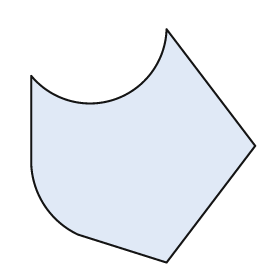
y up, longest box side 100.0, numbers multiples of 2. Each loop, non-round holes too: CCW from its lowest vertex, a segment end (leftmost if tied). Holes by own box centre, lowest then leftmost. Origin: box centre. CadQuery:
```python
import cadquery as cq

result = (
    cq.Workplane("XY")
    .moveTo(10.0, -50.0)
    .lineTo(48.0, 0.0)
    .lineTo(10.0, 50.0)
    .threePointArc((-12.0, 20.0), (-48.0, 30.0))
    .lineTo(-48.0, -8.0)
    .threePointArc((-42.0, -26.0), (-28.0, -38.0))
    .close()
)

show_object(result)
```